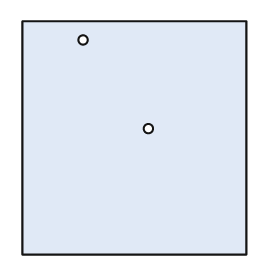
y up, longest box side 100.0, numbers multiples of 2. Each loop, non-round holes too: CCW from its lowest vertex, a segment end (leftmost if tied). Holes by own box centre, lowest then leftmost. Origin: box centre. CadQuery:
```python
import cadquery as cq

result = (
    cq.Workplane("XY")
    .moveTo(-48.0, -50.0)
    .lineTo(48.0, -50.0)
    .lineTo(48.0, 50.0)
    .lineTo(-48.0, 50.0)
    .close()
    .moveTo(6.0, 4.0)
    .circle(2.0)
    .moveTo(-22.0, 42.0)
    .circle(2.0)
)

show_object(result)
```